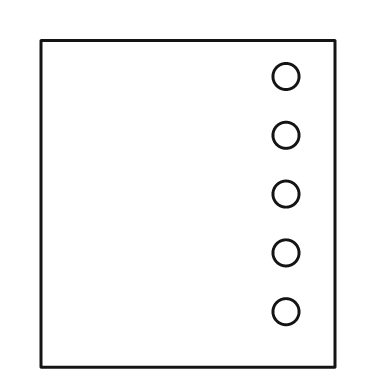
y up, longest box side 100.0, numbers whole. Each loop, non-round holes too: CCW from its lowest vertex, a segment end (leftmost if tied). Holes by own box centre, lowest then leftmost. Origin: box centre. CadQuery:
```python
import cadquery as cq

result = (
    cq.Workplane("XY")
    .moveTo(-45.0, -50.0)
    .lineTo(45.0, -50.0)
    .lineTo(45.0, 50.0)
    .lineTo(-45.0, 50.0)
    .close()
    .moveTo(30.0, -33.0)
    .circle(4.0)
    .moveTo(30.0, -15.0)
    .circle(4.0)
    .moveTo(30.0, 3.0)
    .circle(4.0)
    .moveTo(30.0, 21.0)
    .circle(4.0)
    .moveTo(30.0, 39.0)
    .circle(4.0)
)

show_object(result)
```